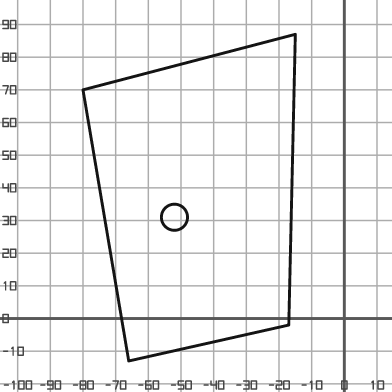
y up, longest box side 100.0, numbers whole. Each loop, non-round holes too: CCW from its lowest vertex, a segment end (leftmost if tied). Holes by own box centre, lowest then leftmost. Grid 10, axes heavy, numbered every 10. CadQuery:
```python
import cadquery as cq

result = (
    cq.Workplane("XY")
    .moveTo(-66.0, -13.0)
    .lineTo(-17.0, -2.0)
    .lineTo(-15.0, 87.0)
    .lineTo(-80.0, 70.0)
    .close()
    .moveTo(-52.0, 31.0)
    .circle(4.0)
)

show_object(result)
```